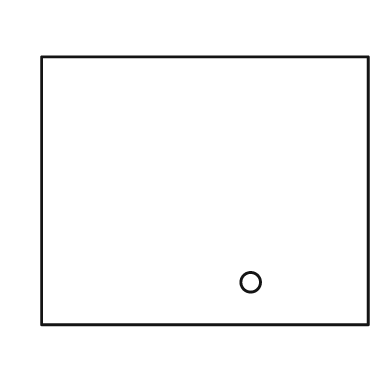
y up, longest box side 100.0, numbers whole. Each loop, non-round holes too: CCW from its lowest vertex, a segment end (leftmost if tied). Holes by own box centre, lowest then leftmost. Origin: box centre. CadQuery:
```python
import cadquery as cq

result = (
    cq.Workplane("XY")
    .moveTo(-50.0, -41.0)
    .lineTo(50.0, -41.0)
    .lineTo(50.0, 41.0)
    .lineTo(-50.0, 41.0)
    .close()
    .moveTo(14.0, -28.0)
    .circle(3.0)
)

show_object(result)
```